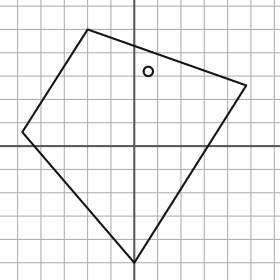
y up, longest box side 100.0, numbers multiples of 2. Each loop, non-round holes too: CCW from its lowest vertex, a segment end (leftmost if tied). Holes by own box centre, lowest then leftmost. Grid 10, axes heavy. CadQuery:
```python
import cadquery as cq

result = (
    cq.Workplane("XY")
    .moveTo(0.0, -50.0)
    .lineTo(48.0, 26.0)
    .lineTo(-20.0, 50.0)
    .lineTo(-48.0, 6.0)
    .close()
    .moveTo(6.0, 32.0)
    .circle(2.0)
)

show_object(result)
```